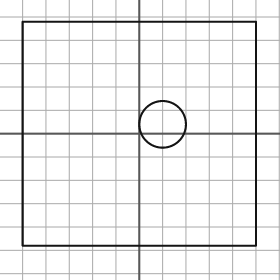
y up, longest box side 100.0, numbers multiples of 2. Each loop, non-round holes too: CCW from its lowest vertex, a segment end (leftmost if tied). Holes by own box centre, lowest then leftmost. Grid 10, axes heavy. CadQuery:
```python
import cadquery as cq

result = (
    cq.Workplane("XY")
    .moveTo(-50.0, -48.0)
    .lineTo(50.0, -48.0)
    .lineTo(50.0, 48.0)
    .lineTo(-50.0, 48.0)
    .close()
    .moveTo(10.0, 4.0)
    .circle(10.0)
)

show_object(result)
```